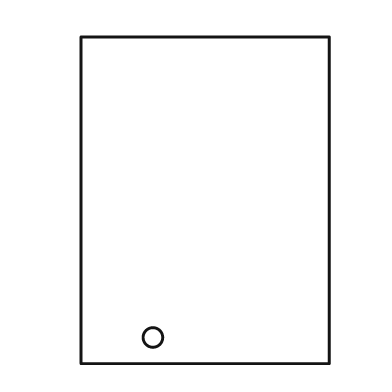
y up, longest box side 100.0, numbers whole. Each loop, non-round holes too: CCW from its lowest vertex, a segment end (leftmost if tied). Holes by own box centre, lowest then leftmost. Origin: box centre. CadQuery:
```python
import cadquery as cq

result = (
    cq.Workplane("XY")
    .moveTo(-38.0, -50.0)
    .lineTo(38.0, -50.0)
    .lineTo(38.0, 50.0)
    .lineTo(-38.0, 50.0)
    .close()
    .moveTo(-16.0, -42.0)
    .circle(3.0)
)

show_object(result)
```